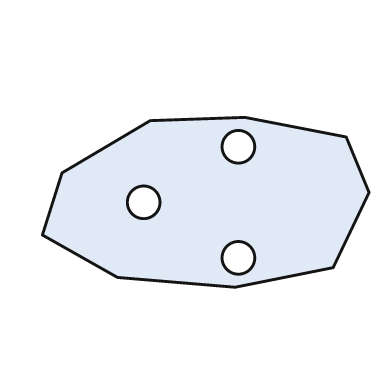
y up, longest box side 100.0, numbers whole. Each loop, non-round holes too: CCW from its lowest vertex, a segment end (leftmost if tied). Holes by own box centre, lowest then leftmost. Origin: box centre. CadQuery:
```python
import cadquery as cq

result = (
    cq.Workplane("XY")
    .moveTo(9.0, -26.0)
    .lineTo(39.0, -20.0)
    .lineTo(50.0, 3.0)
    .lineTo(43.0, 20.0)
    .lineTo(12.0, 26.0)
    .lineTo(-17.0, 25.0)
    .lineTo(-44.0, 9.0)
    .lineTo(-50.0, -10.0)
    .lineTo(-27.0, -23.0)
    .close()
    .moveTo(10.0, -17.0)
    .circle(5.0)
    .moveTo(-19.0, 0.0)
    .circle(5.0)
    .moveTo(10.0, 17.0)
    .circle(5.0)
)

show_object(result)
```